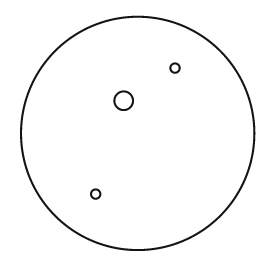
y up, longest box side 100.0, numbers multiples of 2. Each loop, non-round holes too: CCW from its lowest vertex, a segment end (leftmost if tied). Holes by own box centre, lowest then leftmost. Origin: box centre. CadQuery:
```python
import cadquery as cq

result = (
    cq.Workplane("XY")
    .moveTo(0.0, 0.0)
    .circle(50.0)
    .moveTo(-18.0, -26.0)
    .circle(2.0)
    .moveTo(-6.0, 14.0)
    .circle(4.0)
    .moveTo(16.0, 28.0)
    .circle(2.0)
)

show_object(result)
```